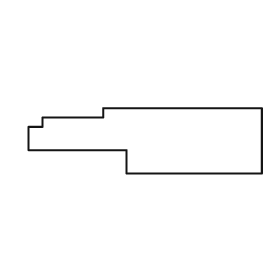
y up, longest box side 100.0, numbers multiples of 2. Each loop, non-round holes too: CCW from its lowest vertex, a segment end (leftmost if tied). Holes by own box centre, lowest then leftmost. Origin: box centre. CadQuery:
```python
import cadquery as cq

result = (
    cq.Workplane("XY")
    .moveTo(-8.0, -14.0)
    .lineTo(50.0, -14.0)
    .lineTo(50.0, 14.0)
    .lineTo(-18.0, 14.0)
    .lineTo(-18.0, 10.0)
    .lineTo(-44.0, 10.0)
    .lineTo(-44.0, 6.0)
    .lineTo(-50.0, 6.0)
    .lineTo(-50.0, -4.0)
    .lineTo(-8.0, -4.0)
    .close()
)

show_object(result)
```